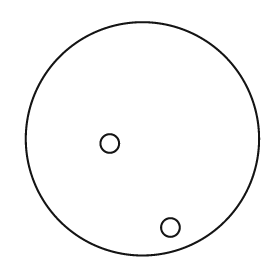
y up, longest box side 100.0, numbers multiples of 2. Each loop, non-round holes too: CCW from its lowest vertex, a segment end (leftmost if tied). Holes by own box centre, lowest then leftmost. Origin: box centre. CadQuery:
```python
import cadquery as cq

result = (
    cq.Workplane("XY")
    .moveTo(0.0, 0.0)
    .circle(50.0)
    .moveTo(12.0, -38.0)
    .circle(4.0)
    .moveTo(-14.0, -2.0)
    .circle(4.0)
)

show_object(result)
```